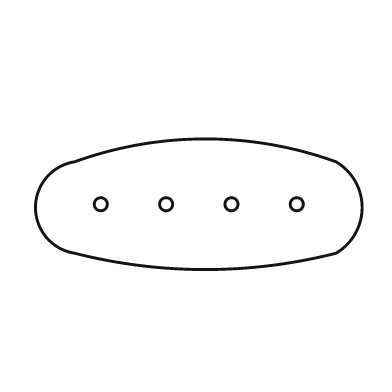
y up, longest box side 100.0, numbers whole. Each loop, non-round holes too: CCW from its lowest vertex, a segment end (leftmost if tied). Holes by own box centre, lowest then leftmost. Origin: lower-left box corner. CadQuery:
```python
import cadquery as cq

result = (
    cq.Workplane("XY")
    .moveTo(12.0, 5.0)
    .threePointArc((52.0, 0.0), (92.0, 5.0))
    .threePointArc((100.0, 19.0), (92.0, 33.0))
    .threePointArc((52.0, 40.0), (12.0, 33.0))
    .threePointArc((0.0, 19.0), (12.0, 5.0))
    .close()
    .moveTo(20.0, 20.0)
    .circle(2.0)
    .moveTo(40.0, 20.0)
    .circle(2.0)
    .moveTo(60.0, 20.0)
    .circle(2.0)
    .moveTo(80.0, 20.0)
    .circle(2.0)
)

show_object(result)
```